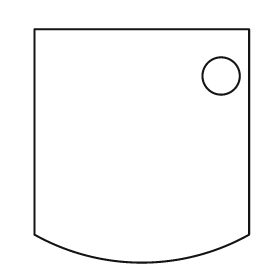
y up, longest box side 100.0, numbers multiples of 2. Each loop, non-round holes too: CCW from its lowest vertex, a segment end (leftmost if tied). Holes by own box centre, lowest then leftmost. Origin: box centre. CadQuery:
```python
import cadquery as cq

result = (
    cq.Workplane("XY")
    .moveTo(-46.0, -38.0)
    .threePointArc((0.0, -50.0), (46.0, -38.0))
    .lineTo(46.0, 50.0)
    .lineTo(-46.0, 50.0)
    .close()
    .moveTo(34.0, 30.0)
    .circle(8.0)
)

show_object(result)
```